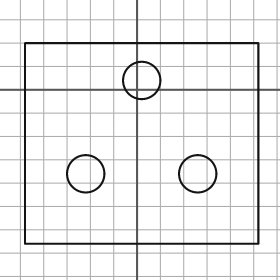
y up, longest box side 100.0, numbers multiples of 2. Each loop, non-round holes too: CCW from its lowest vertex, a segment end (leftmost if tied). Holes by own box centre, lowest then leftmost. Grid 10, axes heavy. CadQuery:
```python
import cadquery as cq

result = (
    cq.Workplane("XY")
    .moveTo(-48.0, -66.0)
    .lineTo(52.0, -66.0)
    .lineTo(52.0, 20.0)
    .lineTo(-48.0, 20.0)
    .close()
    .moveTo(-22.0, -36.0)
    .circle(8.0)
    .moveTo(26.0, -36.0)
    .circle(8.0)
    .moveTo(2.0, 4.0)
    .circle(8.0)
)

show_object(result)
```